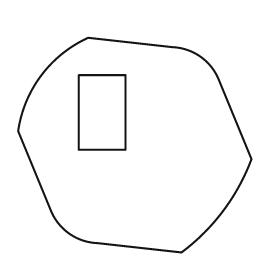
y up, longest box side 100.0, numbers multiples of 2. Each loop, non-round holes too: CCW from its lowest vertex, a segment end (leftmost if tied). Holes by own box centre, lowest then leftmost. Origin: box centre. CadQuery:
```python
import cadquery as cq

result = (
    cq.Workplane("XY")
    .moveTo(20.0, -46.0)
    .threePointArc((38.0, -28.0), (50.0, -6.0))
    .lineTo(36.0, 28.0)
    .threePointArc((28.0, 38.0), (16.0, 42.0))
    .lineTo(-20.0, 46.0)
    .threePointArc((-40.0, 30.0), (-50.0, 6.0))
    .lineTo(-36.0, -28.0)
    .threePointArc((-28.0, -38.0), (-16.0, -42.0))
    .close()
    .moveTo(-24.0, -2.0)
    .lineTo(-4.0, -2.0)
    .lineTo(-4.0, 30.0)
    .lineTo(-24.0, 30.0)
    .close()
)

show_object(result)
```